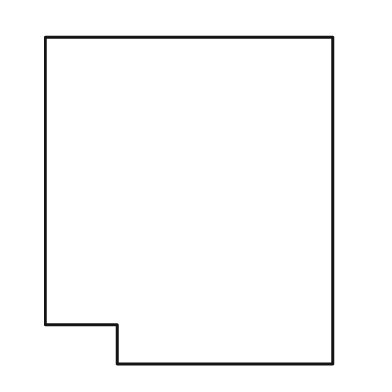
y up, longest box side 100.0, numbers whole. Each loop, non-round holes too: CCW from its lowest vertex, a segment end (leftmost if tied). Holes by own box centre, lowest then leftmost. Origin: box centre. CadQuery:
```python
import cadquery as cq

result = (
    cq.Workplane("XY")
    .moveTo(-22.0, -50.0)
    .lineTo(44.0, -50.0)
    .lineTo(44.0, 50.0)
    .lineTo(-44.0, 50.0)
    .lineTo(-44.0, -38.0)
    .lineTo(-22.0, -38.0)
    .close()
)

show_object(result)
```